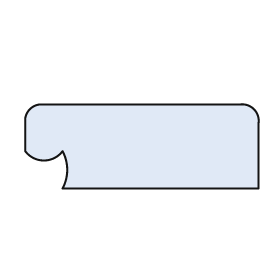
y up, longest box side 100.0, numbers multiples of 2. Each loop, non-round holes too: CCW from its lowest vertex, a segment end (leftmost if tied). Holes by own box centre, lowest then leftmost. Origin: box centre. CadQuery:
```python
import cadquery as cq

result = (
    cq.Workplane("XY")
    .moveTo(-34.0, -18.0)
    .lineTo(50.0, -18.0)
    .lineTo(50.0, 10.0)
    .threePointArc((48.0, 16.0), (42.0, 18.0))
    .lineTo(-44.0, 18.0)
    .threePointArc((-48.0, 16.0), (-50.0, 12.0))
    .lineTo(-50.0, -2.0)
    .threePointArc((-42.0, -6.0), (-34.0, -2.0))
    .threePointArc((-32.0, -10.0), (-34.0, -18.0))
    .close()
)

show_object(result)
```